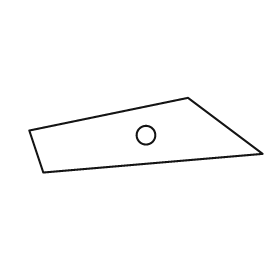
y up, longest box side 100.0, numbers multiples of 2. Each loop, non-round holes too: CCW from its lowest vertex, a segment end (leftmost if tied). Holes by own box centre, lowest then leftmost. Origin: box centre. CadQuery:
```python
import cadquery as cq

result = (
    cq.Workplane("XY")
    .moveTo(-44.0, -16.0)
    .lineTo(50.0, -8.0)
    .lineTo(18.0, 16.0)
    .lineTo(-50.0, 2.0)
    .close()
    .moveTo(0.0, 0.0)
    .circle(4.0)
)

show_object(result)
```